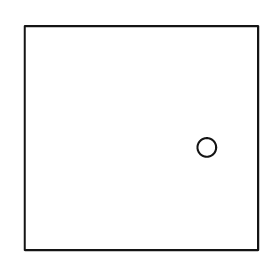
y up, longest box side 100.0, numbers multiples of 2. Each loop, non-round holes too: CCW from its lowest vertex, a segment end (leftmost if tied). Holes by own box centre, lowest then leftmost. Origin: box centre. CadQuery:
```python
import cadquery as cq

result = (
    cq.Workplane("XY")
    .moveTo(-50.0, -48.0)
    .lineTo(50.0, -48.0)
    .lineTo(50.0, 48.0)
    .lineTo(-50.0, 48.0)
    .close()
    .moveTo(28.0, -4.0)
    .circle(4.0)
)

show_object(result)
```